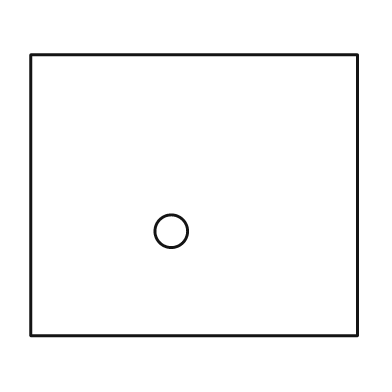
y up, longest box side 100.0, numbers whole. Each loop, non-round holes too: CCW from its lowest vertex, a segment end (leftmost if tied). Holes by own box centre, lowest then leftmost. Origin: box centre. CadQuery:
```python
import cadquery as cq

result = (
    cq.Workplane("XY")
    .moveTo(-50.0, -43.0)
    .lineTo(50.0, -43.0)
    .lineTo(50.0, 43.0)
    .lineTo(-50.0, 43.0)
    .close()
    .moveTo(-7.0, -11.0)
    .circle(5.0)
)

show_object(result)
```